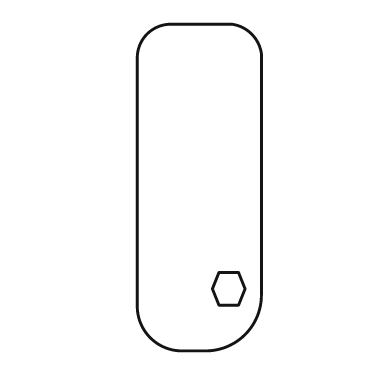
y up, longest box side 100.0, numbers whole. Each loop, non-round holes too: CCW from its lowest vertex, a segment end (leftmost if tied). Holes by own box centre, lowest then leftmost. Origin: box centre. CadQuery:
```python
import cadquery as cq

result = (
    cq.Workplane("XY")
    .moveTo(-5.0, -50.0)
    .lineTo(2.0, -50.0)
    .threePointArc((14.0, -45.0), (19.0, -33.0))
    .lineTo(19.0, 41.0)
    .threePointArc((16.0, 47.0), (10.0, 50.0))
    .lineTo(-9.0, 50.0)
    .threePointArc((-16.0, 47.0), (-19.0, 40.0))
    .lineTo(-19.0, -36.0)
    .threePointArc((-15.0, -46.0), (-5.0, -50.0))
    .close()
    .moveTo(6.0, -36.0)
    .lineTo(12.0, -36.0)
    .lineTo(14.0, -31.0)
    .lineTo(12.0, -26.0)
    .lineTo(6.0, -26.0)
    .lineTo(4.0, -31.0)
    .close()
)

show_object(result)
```